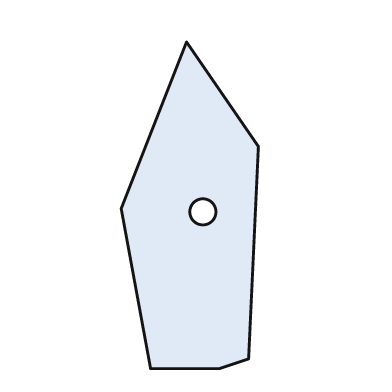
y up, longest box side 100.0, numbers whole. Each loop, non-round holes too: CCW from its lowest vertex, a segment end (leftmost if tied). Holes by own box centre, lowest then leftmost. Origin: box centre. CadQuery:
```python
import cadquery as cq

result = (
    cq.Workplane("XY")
    .moveTo(-12.0, -50.0)
    .lineTo(9.0, -50.0)
    .lineTo(18.0, -47.0)
    .lineTo(21.0, 18.0)
    .lineTo(-1.0, 50.0)
    .lineTo(-21.0, -1.0)
    .close()
    .moveTo(4.0, -2.0)
    .circle(4.0)
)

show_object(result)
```